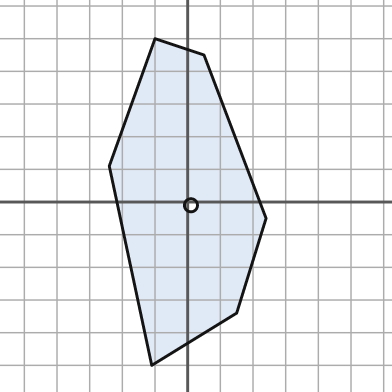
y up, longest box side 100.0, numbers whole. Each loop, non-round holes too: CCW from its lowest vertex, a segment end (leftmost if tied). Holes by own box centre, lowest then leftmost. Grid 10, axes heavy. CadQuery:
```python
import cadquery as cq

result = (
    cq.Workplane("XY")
    .moveTo(-11.0, -50.0)
    .lineTo(15.0, -34.0)
    .lineTo(24.0, -5.0)
    .lineTo(5.0, 45.0)
    .lineTo(-10.0, 50.0)
    .lineTo(-24.0, 11.0)
    .close()
    .moveTo(1.0, -1.0)
    .circle(2.0)
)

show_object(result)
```